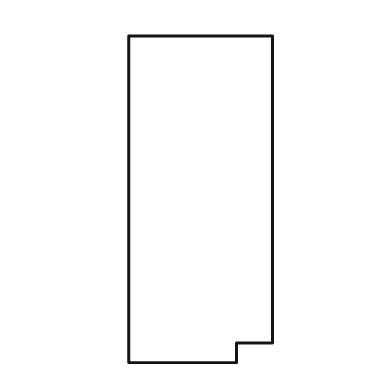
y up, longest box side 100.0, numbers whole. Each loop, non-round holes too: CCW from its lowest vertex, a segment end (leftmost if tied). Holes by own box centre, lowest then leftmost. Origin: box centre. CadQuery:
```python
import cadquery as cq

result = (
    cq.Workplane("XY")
    .moveTo(-22.0, -50.0)
    .lineTo(11.0, -50.0)
    .lineTo(11.0, -44.0)
    .lineTo(22.0, -44.0)
    .lineTo(22.0, 50.0)
    .lineTo(-22.0, 50.0)
    .close()
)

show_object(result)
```